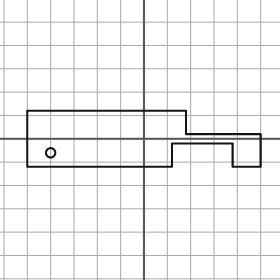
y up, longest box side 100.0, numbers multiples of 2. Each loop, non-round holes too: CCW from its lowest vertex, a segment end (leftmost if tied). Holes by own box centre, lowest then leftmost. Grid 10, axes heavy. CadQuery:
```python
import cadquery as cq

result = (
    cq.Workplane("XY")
    .moveTo(-50.0, -12.0)
    .lineTo(12.0, -12.0)
    .lineTo(12.0, -2.0)
    .lineTo(38.0, -2.0)
    .lineTo(38.0, -12.0)
    .lineTo(50.0, -12.0)
    .lineTo(50.0, 2.0)
    .lineTo(18.0, 2.0)
    .lineTo(18.0, 12.0)
    .lineTo(-50.0, 12.0)
    .close()
    .moveTo(-40.0, -6.0)
    .circle(2.0)
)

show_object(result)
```